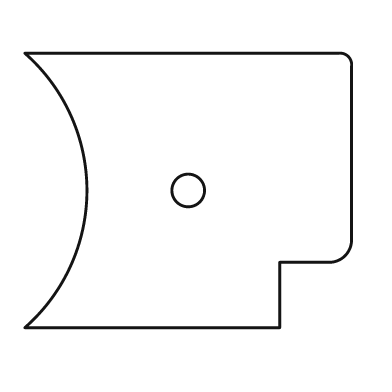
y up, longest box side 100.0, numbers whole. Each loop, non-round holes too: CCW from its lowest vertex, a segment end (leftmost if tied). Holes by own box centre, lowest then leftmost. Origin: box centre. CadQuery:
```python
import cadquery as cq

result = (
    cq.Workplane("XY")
    .moveTo(-50.0, -42.0)
    .lineTo(28.0, -42.0)
    .lineTo(28.0, -22.0)
    .lineTo(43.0, -22.0)
    .threePointArc((48.0, -20.0), (50.0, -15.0))
    .lineTo(50.0, 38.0)
    .threePointArc((49.0, 41.0), (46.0, 42.0))
    .lineTo(-50.0, 42.0)
    .threePointArc((-31.0, 0.0), (-50.0, -42.0))
    .close()
    .moveTo(0.0, 0.0)
    .circle(5.0)
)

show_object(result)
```